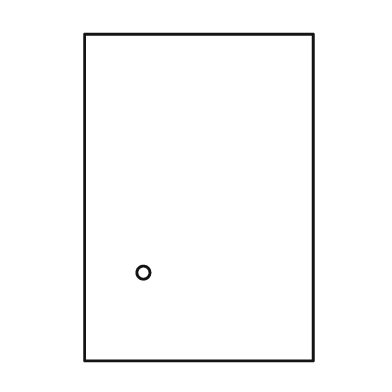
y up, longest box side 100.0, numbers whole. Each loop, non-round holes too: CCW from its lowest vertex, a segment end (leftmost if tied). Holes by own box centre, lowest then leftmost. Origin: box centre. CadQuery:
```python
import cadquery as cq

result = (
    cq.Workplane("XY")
    .moveTo(-35.0, -50.0)
    .lineTo(35.0, -50.0)
    .lineTo(35.0, 50.0)
    .lineTo(-35.0, 50.0)
    .close()
    .moveTo(-17.0, -23.0)
    .circle(2.0)
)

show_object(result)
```